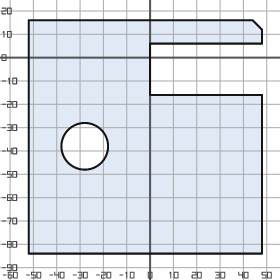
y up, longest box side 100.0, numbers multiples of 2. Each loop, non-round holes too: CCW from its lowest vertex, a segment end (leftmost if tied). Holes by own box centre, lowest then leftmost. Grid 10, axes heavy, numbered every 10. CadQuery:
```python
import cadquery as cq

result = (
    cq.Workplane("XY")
    .moveTo(-52.0, -84.0)
    .lineTo(48.0, -84.0)
    .lineTo(48.0, -16.0)
    .lineTo(0.0, -16.0)
    .lineTo(0.0, 6.0)
    .lineTo(48.0, 6.0)
    .lineTo(48.0, 12.0)
    .lineTo(44.0, 16.0)
    .lineTo(-52.0, 16.0)
    .close()
    .moveTo(-28.0, -38.0)
    .circle(10.0)
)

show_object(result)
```